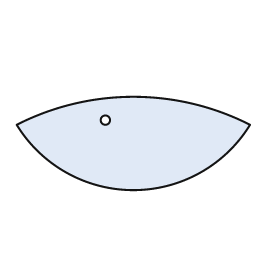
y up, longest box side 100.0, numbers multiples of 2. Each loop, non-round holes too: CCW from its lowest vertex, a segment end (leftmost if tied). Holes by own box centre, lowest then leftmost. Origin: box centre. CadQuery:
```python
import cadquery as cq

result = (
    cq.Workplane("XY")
    .moveTo(-50.0, 8.0)
    .threePointArc((0.0, -20.0), (50.0, 8.0))
    .threePointArc((0.0, 20.0), (-50.0, 8.0))
    .close()
    .moveTo(-12.0, 10.0)
    .circle(2.0)
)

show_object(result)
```